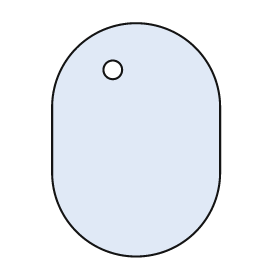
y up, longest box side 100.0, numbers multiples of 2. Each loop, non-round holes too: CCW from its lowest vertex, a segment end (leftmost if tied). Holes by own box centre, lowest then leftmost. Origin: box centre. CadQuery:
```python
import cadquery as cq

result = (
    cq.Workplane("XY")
    .moveTo(-36.0, -14.0)
    .threePointArc((0.0, -50.0), (36.0, -14.0))
    .lineTo(36.0, 14.0)
    .threePointArc((0.0, 50.0), (-36.0, 14.0))
    .close()
    .moveTo(-10.0, 30.0)
    .circle(4.0)
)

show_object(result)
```